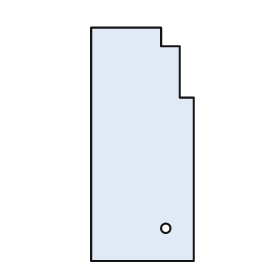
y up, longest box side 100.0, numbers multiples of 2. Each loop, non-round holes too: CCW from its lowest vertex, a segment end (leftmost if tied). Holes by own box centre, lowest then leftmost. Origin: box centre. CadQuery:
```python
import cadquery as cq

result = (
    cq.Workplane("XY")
    .moveTo(-22.0, -50.0)
    .lineTo(22.0, -50.0)
    .lineTo(22.0, 20.0)
    .lineTo(16.0, 20.0)
    .lineTo(16.0, 42.0)
    .lineTo(8.0, 42.0)
    .lineTo(8.0, 50.0)
    .lineTo(-22.0, 50.0)
    .close()
    .moveTo(10.0, -36.0)
    .circle(2.0)
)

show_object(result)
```